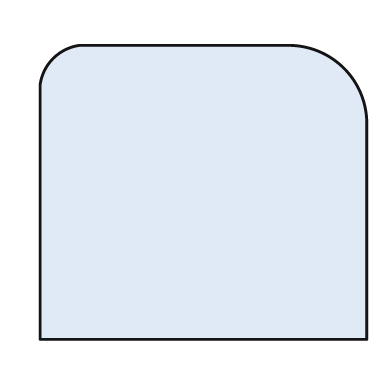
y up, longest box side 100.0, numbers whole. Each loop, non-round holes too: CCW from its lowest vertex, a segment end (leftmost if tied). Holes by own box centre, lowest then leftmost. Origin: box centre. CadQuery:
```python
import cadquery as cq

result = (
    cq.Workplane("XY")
    .moveTo(-50.0, -45.0)
    .lineTo(50.0, -45.0)
    .lineTo(50.0, 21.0)
    .threePointArc((43.0, 38.0), (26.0, 45.0))
    .lineTo(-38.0, 45.0)
    .threePointArc((-46.0, 41.0), (-50.0, 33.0))
    .close()
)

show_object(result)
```